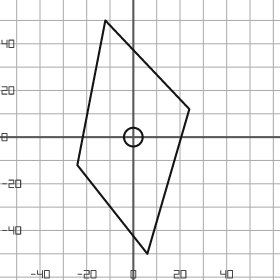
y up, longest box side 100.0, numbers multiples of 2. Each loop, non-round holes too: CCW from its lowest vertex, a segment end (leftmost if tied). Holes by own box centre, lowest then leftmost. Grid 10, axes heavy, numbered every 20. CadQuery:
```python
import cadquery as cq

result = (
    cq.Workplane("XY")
    .moveTo(6.0, -50.0)
    .lineTo(24.0, 12.0)
    .lineTo(-12.0, 50.0)
    .lineTo(-24.0, -12.0)
    .close()
    .moveTo(0.0, 0.0)
    .circle(4.0)
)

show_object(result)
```